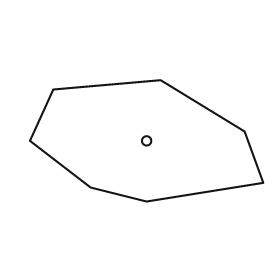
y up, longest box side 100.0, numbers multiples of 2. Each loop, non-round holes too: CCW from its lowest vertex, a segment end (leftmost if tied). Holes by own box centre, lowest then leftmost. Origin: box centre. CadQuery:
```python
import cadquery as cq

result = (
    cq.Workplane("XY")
    .moveTo(0.0, -26.0)
    .lineTo(50.0, -18.0)
    .lineTo(42.0, 4.0)
    .lineTo(6.0, 26.0)
    .lineTo(-40.0, 22.0)
    .lineTo(-50.0, 0.0)
    .lineTo(-24.0, -20.0)
    .close()
    .moveTo(0.0, 0.0)
    .circle(2.0)
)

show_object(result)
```